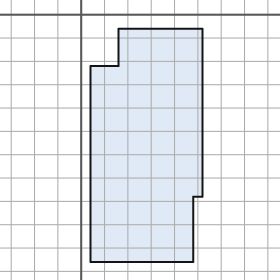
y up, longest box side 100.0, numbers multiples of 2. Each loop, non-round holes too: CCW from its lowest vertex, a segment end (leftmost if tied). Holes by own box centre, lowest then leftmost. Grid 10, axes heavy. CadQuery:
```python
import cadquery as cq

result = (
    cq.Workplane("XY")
    .moveTo(4.0, -106.0)
    .lineTo(48.0, -106.0)
    .lineTo(48.0, -78.0)
    .lineTo(52.0, -78.0)
    .lineTo(52.0, -6.0)
    .lineTo(16.0, -6.0)
    .lineTo(16.0, -22.0)
    .lineTo(4.0, -22.0)
    .close()
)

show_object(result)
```